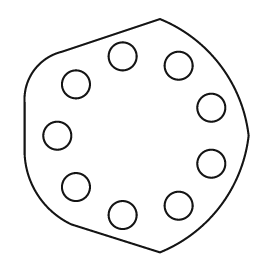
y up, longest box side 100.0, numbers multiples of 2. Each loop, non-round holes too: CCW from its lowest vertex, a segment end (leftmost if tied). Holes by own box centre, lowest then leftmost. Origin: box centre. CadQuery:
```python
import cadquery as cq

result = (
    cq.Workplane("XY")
    .moveTo(10.0, -50.0)
    .threePointArc((36.0, -30.0), (48.0, 0.0))
    .threePointArc((36.0, 30.0), (10.0, 50.0))
    .lineTo(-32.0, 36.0)
    .threePointArc((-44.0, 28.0), (-48.0, 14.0))
    .lineTo(-48.0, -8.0)
    .threePointArc((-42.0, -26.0), (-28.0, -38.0))
    .close()
    .moveTo(-6.0, -34.0)
    .circle(6.0)
    .moveTo(18.0, -30.0)
    .circle(6.0)
    .moveTo(-26.0, -22.0)
    .circle(6.0)
    .moveTo(32.0, -12.0)
    .circle(6.0)
    .moveTo(-34.0, 0.0)
    .circle(6.0)
    .moveTo(32.0, 12.0)
    .circle(6.0)
    .moveTo(-26.0, 22.0)
    .circle(6.0)
    .moveTo(18.0, 30.0)
    .circle(6.0)
    .moveTo(-6.0, 34.0)
    .circle(6.0)
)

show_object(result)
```